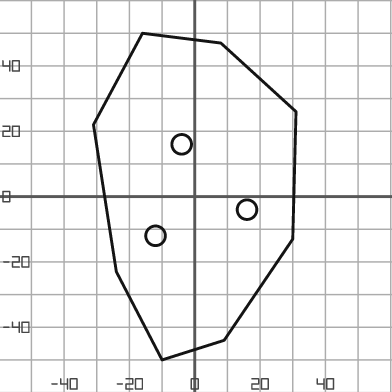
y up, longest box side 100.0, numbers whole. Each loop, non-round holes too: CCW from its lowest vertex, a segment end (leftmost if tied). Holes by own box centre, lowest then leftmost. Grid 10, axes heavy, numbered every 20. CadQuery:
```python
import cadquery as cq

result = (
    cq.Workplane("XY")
    .moveTo(-10.0, -50.0)
    .lineTo(9.0, -44.0)
    .lineTo(30.0, -13.0)
    .lineTo(31.0, 26.0)
    .lineTo(8.0, 47.0)
    .lineTo(-16.0, 50.0)
    .lineTo(-31.0, 22.0)
    .lineTo(-24.0, -23.0)
    .close()
    .moveTo(-12.0, -12.0)
    .circle(3.0)
    .moveTo(16.0, -4.0)
    .circle(3.0)
    .moveTo(-4.0, 16.0)
    .circle(3.0)
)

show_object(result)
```